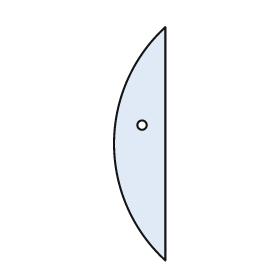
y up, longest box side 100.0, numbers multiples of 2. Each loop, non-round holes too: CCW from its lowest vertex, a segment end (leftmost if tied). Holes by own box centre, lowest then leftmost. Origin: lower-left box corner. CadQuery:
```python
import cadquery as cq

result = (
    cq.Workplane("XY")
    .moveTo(22.0, 0.0)
    .lineTo(22.0, 100.0)
    .threePointArc((0.0, 50.0), (22.0, 0.0))
    .close()
    .moveTo(12.0, 58.0)
    .circle(2.0)
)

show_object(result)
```